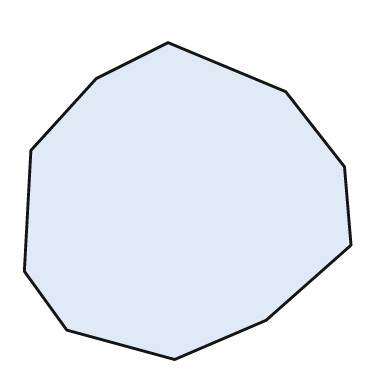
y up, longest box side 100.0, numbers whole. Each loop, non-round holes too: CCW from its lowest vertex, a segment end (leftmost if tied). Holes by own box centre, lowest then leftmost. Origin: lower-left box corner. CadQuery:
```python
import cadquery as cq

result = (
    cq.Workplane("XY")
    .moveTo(46.0, 0.0)
    .lineTo(74.0, 12.0)
    .lineTo(100.0, 35.0)
    .lineTo(98.0, 59.0)
    .lineTo(80.0, 82.0)
    .lineTo(44.0, 97.0)
    .lineTo(22.0, 86.0)
    .lineTo(2.0, 64.0)
    .lineTo(0.0, 27.0)
    .lineTo(13.0, 9.0)
    .close()
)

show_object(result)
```